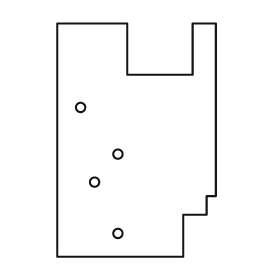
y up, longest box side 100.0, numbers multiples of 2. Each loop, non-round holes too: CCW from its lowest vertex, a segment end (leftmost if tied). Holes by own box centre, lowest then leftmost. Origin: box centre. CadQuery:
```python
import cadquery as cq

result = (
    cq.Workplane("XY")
    .moveTo(-34.0, -50.0)
    .lineTo(20.0, -50.0)
    .lineTo(20.0, -32.0)
    .lineTo(30.0, -32.0)
    .lineTo(30.0, -24.0)
    .lineTo(34.0, -24.0)
    .lineTo(34.0, 50.0)
    .lineTo(24.0, 50.0)
    .lineTo(24.0, 28.0)
    .lineTo(-4.0, 28.0)
    .lineTo(-4.0, 50.0)
    .lineTo(-34.0, 50.0)
    .close()
    .moveTo(-8.0, -40.0)
    .circle(2.0)
    .moveTo(-18.0, -18.0)
    .circle(2.0)
    .moveTo(-8.0, -6.0)
    .circle(2.0)
    .moveTo(-24.0, 14.0)
    .circle(2.0)
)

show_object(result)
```